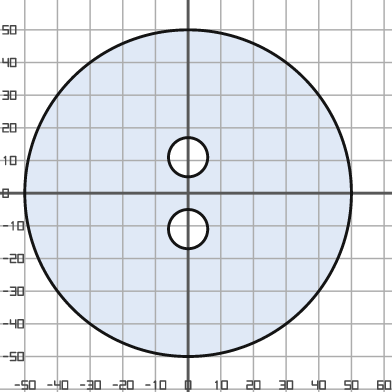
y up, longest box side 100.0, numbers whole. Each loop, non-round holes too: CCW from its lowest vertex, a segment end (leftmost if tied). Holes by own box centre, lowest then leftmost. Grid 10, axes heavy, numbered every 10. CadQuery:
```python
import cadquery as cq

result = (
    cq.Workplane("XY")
    .moveTo(0.0, 0.0)
    .circle(50.0)
    .moveTo(0.0, -11.0)
    .circle(6.0)
    .moveTo(0.0, 11.0)
    .circle(6.0)
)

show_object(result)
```